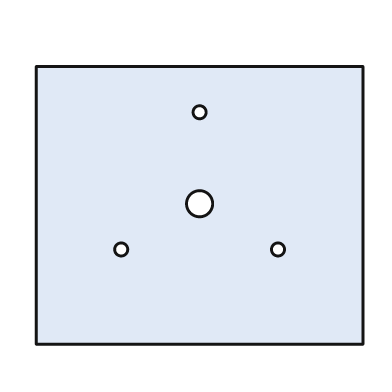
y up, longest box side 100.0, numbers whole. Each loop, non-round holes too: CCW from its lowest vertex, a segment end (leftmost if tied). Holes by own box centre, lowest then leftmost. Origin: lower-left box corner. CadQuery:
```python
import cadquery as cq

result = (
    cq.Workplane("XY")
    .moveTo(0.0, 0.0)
    .lineTo(100.0, 0.0)
    .lineTo(100.0, 85.0)
    .lineTo(0.0, 85.0)
    .close()
    .moveTo(26.0, 29.0)
    .circle(2.0)
    .moveTo(74.0, 29.0)
    .circle(2.0)
    .moveTo(50.0, 43.0)
    .circle(4.0)
    .moveTo(50.0, 71.0)
    .circle(2.0)
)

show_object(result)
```